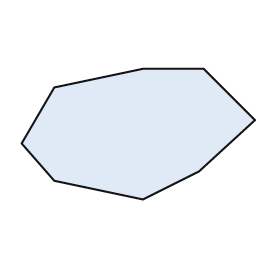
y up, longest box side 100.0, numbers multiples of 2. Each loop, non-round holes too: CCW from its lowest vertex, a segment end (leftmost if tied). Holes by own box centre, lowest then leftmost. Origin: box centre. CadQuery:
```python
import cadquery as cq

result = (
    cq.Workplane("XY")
    .moveTo(2.0, -28.0)
    .lineTo(26.0, -16.0)
    .lineTo(50.0, 6.0)
    .lineTo(28.0, 28.0)
    .lineTo(2.0, 28.0)
    .lineTo(-36.0, 20.0)
    .lineTo(-50.0, -4.0)
    .lineTo(-36.0, -20.0)
    .close()
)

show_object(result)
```